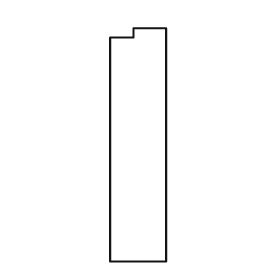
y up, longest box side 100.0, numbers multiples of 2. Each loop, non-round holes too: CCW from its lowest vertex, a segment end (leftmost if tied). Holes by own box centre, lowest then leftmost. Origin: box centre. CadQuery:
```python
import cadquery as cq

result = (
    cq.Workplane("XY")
    .moveTo(-12.0, -50.0)
    .lineTo(12.0, -50.0)
    .lineTo(12.0, 50.0)
    .lineTo(-2.0, 50.0)
    .lineTo(-2.0, 46.0)
    .lineTo(-12.0, 46.0)
    .close()
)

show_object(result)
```